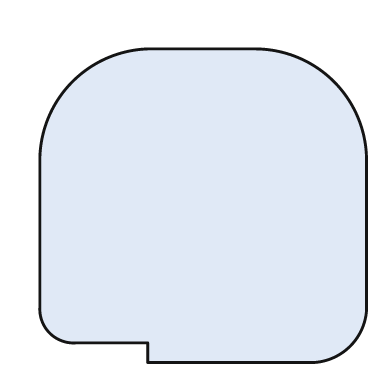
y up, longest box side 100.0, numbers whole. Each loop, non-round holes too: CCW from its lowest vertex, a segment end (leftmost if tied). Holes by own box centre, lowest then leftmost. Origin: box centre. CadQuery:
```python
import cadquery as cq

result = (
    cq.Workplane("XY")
    .moveTo(-17.0, -48.0)
    .lineTo(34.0, -48.0)
    .threePointArc((45.0, -43.0), (50.0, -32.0))
    .lineTo(50.0, 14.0)
    .threePointArc((40.0, 38.0), (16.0, 48.0))
    .lineTo(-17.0, 48.0)
    .threePointArc((-40.0, 38.0), (-50.0, 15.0))
    .lineTo(-50.0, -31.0)
    .threePointArc((-47.0, -39.0), (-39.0, -42.0))
    .lineTo(-17.0, -42.0)
    .close()
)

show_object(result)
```